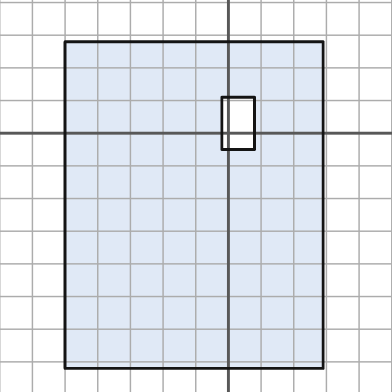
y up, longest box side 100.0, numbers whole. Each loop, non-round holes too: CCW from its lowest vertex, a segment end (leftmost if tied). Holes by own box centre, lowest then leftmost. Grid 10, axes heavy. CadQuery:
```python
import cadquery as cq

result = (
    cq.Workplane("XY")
    .moveTo(-50.0, -72.0)
    .lineTo(29.0, -72.0)
    .lineTo(29.0, 28.0)
    .lineTo(-50.0, 28.0)
    .close()
    .moveTo(-2.0, -5.0)
    .lineTo(8.0, -5.0)
    .lineTo(8.0, 11.0)
    .lineTo(-2.0, 11.0)
    .close()
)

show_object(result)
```